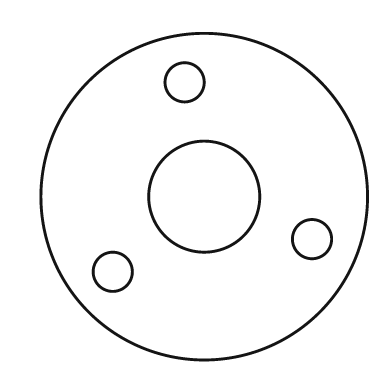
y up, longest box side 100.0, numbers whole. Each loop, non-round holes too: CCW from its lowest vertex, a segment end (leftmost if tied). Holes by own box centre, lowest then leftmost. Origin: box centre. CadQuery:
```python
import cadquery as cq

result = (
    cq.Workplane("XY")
    .moveTo(0.0, 0.0)
    .circle(50.0)
    .moveTo(-28.0, -23.0)
    .circle(6.0)
    .moveTo(33.0, -13.0)
    .circle(6.0)
    .moveTo(0.0, 0.0)
    .circle(17.0)
    .moveTo(-6.0, 35.0)
    .circle(6.0)
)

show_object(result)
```